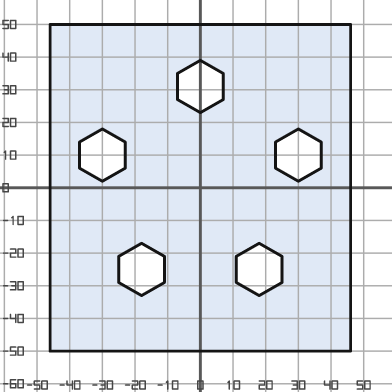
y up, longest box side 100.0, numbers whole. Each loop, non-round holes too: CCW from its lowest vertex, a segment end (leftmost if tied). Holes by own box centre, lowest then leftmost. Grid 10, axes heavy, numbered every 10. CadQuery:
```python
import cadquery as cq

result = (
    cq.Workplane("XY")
    .moveTo(-46.0, -50.0)
    .lineTo(46.0, -50.0)
    .lineTo(46.0, 50.0)
    .lineTo(-46.0, 50.0)
    .close()
    .moveTo(-18.0, -33.0)
    .lineTo(-11.0, -29.0)
    .lineTo(-11.0, -21.0)
    .lineTo(-18.0, -17.0)
    .lineTo(-25.0, -21.0)
    .lineTo(-25.0, -29.0)
    .close()
    .moveTo(18.0, -33.0)
    .lineTo(25.0, -29.0)
    .lineTo(25.0, -21.0)
    .lineTo(18.0, -17.0)
    .lineTo(11.0, -21.0)
    .lineTo(11.0, -29.0)
    .close()
    .moveTo(-30.0, 2.0)
    .lineTo(-23.0, 6.0)
    .lineTo(-23.0, 14.0)
    .lineTo(-30.0, 18.0)
    .lineTo(-37.0, 14.0)
    .lineTo(-37.0, 6.0)
    .close()
    .moveTo(30.0, 2.0)
    .lineTo(37.0, 6.0)
    .lineTo(37.0, 14.0)
    .lineTo(30.0, 18.0)
    .lineTo(23.0, 14.0)
    .lineTo(23.0, 6.0)
    .close()
    .moveTo(0.0, 23.0)
    .lineTo(7.0, 27.0)
    .lineTo(7.0, 35.0)
    .lineTo(0.0, 39.0)
    .lineTo(-7.0, 35.0)
    .lineTo(-7.0, 27.0)
    .close()
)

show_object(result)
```